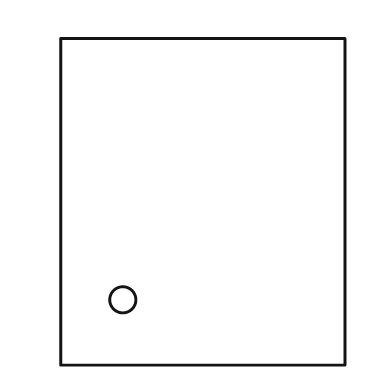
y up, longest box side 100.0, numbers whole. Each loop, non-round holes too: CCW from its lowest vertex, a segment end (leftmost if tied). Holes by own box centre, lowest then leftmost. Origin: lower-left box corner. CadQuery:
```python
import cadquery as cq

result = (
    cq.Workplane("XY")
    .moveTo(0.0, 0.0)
    .lineTo(87.0, 0.0)
    .lineTo(87.0, 100.0)
    .lineTo(0.0, 100.0)
    .close()
    .moveTo(19.0, 20.0)
    .circle(4.0)
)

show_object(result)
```